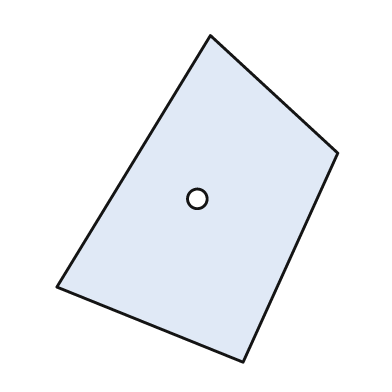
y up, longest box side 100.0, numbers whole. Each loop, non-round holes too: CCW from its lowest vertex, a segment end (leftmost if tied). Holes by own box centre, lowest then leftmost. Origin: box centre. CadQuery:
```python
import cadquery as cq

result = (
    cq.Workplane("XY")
    .moveTo(14.0, -50.0)
    .lineTo(43.0, 14.0)
    .lineTo(4.0, 50.0)
    .lineTo(-43.0, -27.0)
    .close()
    .moveTo(0.0, 0.0)
    .circle(3.0)
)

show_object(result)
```